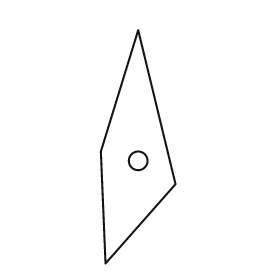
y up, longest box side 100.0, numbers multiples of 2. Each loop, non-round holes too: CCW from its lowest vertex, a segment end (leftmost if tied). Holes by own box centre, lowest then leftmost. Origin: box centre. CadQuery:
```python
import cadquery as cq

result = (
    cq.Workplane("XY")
    .moveTo(-14.0, -50.0)
    .lineTo(16.0, -16.0)
    .lineTo(0.0, 50.0)
    .lineTo(-16.0, -2.0)
    .close()
    .moveTo(0.0, -6.0)
    .circle(4.0)
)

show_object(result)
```